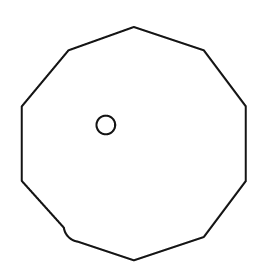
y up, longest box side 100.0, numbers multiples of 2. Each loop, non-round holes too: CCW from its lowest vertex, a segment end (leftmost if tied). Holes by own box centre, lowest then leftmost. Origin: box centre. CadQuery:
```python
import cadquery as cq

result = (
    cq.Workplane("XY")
    .moveTo(0.0, -50.0)
    .lineTo(30.0, -40.0)
    .lineTo(48.0, -16.0)
    .lineTo(48.0, 16.0)
    .lineTo(30.0, 40.0)
    .lineTo(0.0, 50.0)
    .lineTo(-28.0, 40.0)
    .lineTo(-48.0, 16.0)
    .lineTo(-48.0, -16.0)
    .lineTo(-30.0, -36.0)
    .threePointArc((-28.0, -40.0), (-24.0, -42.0))
    .close()
    .moveTo(-12.0, 8.0)
    .circle(4.0)
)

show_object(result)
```